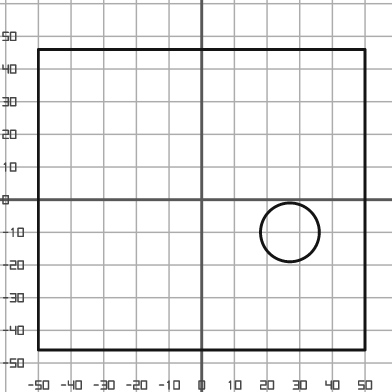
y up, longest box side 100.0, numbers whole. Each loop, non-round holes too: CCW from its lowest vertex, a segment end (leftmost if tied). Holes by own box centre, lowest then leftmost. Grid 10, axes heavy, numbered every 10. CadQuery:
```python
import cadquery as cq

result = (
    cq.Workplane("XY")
    .moveTo(-50.0, -46.0)
    .lineTo(50.0, -46.0)
    .lineTo(50.0, 46.0)
    .lineTo(-50.0, 46.0)
    .close()
    .moveTo(27.0, -10.0)
    .circle(9.0)
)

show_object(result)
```